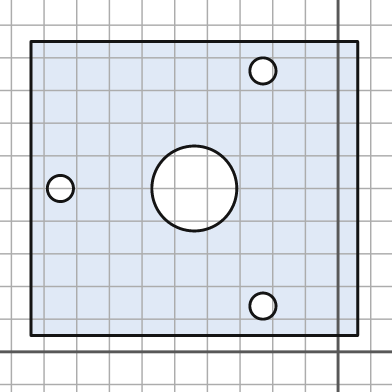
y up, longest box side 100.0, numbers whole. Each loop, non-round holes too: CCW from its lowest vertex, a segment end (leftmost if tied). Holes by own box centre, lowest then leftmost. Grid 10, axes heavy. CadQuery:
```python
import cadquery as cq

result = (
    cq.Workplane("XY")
    .moveTo(-94.0, 5.0)
    .lineTo(6.0, 5.0)
    .lineTo(6.0, 95.0)
    .lineTo(-94.0, 95.0)
    .close()
    .moveTo(-23.0, 14.0)
    .circle(4.0)
    .moveTo(-85.0, 50.0)
    .circle(4.0)
    .moveTo(-44.0, 50.0)
    .circle(13.0)
    .moveTo(-23.0, 86.0)
    .circle(4.0)
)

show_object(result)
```